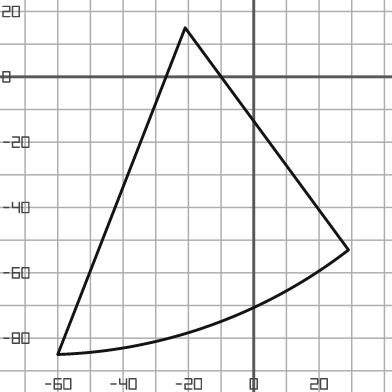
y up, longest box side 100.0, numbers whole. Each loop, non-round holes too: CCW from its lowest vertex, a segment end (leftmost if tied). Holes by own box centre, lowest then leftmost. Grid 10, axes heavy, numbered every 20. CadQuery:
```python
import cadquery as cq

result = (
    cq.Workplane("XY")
    .moveTo(-60.0, -85.0)
    .threePointArc((-13.0, -76.0), (29.0, -53.0))
    .lineTo(-21.0, 15.0)
    .close()
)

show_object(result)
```